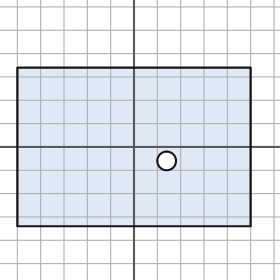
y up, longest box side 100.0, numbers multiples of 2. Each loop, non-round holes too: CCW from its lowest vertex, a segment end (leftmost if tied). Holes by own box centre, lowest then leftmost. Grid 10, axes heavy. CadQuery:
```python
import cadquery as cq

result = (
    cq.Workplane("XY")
    .moveTo(-50.0, -34.0)
    .lineTo(50.0, -34.0)
    .lineTo(50.0, 34.0)
    .lineTo(-50.0, 34.0)
    .close()
    .moveTo(14.0, -6.0)
    .circle(4.0)
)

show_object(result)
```